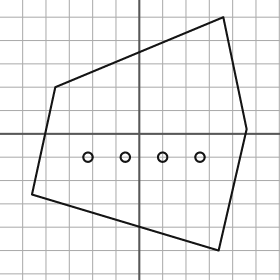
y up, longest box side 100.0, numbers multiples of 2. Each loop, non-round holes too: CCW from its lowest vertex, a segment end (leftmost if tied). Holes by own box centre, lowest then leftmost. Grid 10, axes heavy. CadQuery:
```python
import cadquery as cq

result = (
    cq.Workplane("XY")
    .moveTo(34.0, -50.0)
    .lineTo(46.0, 2.0)
    .lineTo(36.0, 50.0)
    .lineTo(-36.0, 20.0)
    .lineTo(-46.0, -26.0)
    .close()
    .moveTo(-22.0, -10.0)
    .circle(2.0)
    .moveTo(-6.0, -10.0)
    .circle(2.0)
    .moveTo(10.0, -10.0)
    .circle(2.0)
    .moveTo(26.0, -10.0)
    .circle(2.0)
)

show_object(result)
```